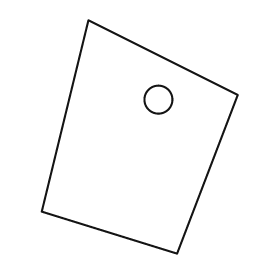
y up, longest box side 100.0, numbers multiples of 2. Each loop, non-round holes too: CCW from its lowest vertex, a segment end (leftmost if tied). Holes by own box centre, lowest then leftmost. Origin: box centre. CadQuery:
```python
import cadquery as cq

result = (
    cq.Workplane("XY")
    .moveTo(16.0, -50.0)
    .lineTo(42.0, 18.0)
    .lineTo(-22.0, 50.0)
    .lineTo(-42.0, -32.0)
    .close()
    .moveTo(8.0, 16.0)
    .circle(6.0)
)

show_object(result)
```